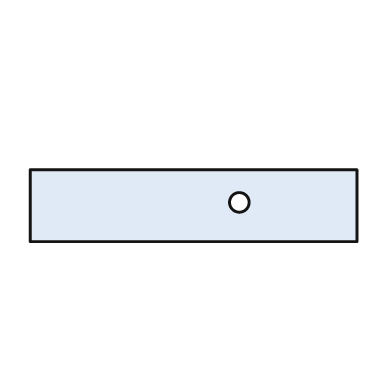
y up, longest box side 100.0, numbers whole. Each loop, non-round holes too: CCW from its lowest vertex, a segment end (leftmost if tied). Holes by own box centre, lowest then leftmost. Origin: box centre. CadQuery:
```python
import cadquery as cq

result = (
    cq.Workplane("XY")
    .moveTo(-50.0, -11.0)
    .lineTo(50.0, -11.0)
    .lineTo(50.0, 11.0)
    .lineTo(-50.0, 11.0)
    .close()
    .moveTo(14.0, 1.0)
    .circle(3.0)
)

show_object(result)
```